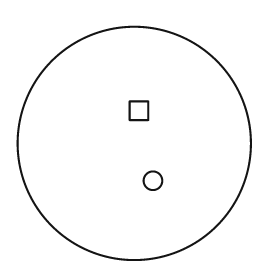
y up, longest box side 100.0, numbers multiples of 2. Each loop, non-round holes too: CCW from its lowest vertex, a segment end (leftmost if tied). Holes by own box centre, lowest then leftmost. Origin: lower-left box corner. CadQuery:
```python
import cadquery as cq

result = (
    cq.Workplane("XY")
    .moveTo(50.0, 50.0)
    .circle(50.0)
    .moveTo(58.0, 34.0)
    .circle(4.0)
    .moveTo(48.0, 60.0)
    .lineTo(56.0, 60.0)
    .lineTo(56.0, 68.0)
    .lineTo(48.0, 68.0)
    .close()
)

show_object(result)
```